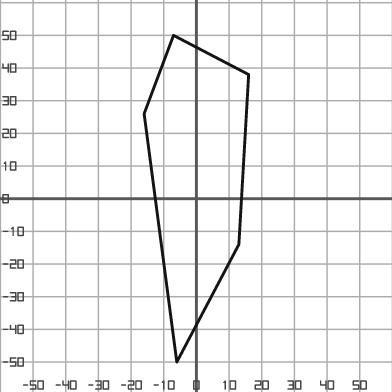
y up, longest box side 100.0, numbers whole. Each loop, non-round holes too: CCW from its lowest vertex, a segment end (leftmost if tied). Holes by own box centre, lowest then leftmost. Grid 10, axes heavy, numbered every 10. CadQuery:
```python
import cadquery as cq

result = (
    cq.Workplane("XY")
    .moveTo(-6.0, -50.0)
    .lineTo(13.0, -14.0)
    .lineTo(16.0, 38.0)
    .lineTo(-7.0, 50.0)
    .lineTo(-16.0, 26.0)
    .close()
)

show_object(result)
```